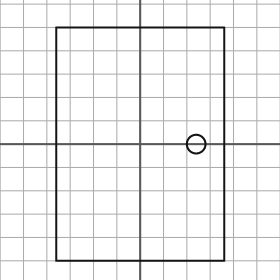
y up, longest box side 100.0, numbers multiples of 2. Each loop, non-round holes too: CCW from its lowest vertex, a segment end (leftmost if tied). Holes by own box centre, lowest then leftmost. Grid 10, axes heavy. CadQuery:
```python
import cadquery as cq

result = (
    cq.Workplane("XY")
    .moveTo(-36.0, -50.0)
    .lineTo(36.0, -50.0)
    .lineTo(36.0, 50.0)
    .lineTo(-36.0, 50.0)
    .close()
    .moveTo(24.0, 0.0)
    .circle(4.0)
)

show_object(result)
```